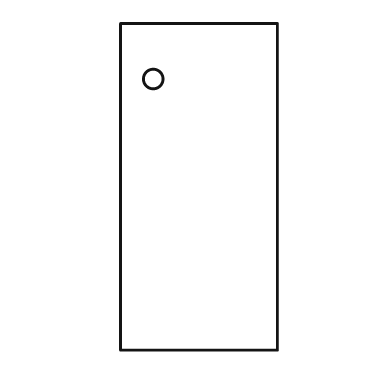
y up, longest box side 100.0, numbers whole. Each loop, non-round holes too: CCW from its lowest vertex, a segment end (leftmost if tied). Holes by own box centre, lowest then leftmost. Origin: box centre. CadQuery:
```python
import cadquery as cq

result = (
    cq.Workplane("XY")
    .moveTo(-24.0, -50.0)
    .lineTo(24.0, -50.0)
    .lineTo(24.0, 50.0)
    .lineTo(-24.0, 50.0)
    .close()
    .moveTo(-14.0, 33.0)
    .circle(3.0)
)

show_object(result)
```